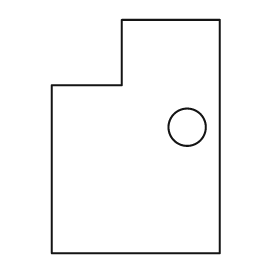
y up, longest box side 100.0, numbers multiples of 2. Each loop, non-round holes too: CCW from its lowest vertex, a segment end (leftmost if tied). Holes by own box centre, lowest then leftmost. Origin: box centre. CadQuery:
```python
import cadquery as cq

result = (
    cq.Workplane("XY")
    .moveTo(-36.0, -50.0)
    .lineTo(36.0, -50.0)
    .lineTo(36.0, 50.0)
    .lineTo(-6.0, 50.0)
    .lineTo(-6.0, 22.0)
    .lineTo(-36.0, 22.0)
    .close()
    .moveTo(22.0, 4.0)
    .circle(8.0)
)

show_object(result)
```